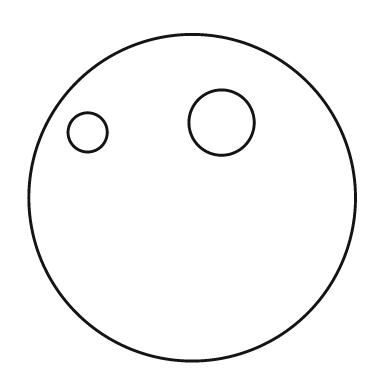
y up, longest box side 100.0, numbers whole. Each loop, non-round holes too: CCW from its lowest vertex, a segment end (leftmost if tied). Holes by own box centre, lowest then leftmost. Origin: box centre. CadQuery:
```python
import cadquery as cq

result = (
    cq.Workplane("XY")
    .moveTo(0.0, 0.0)
    .circle(50.0)
    .moveTo(-32.0, 20.0)
    .circle(6.0)
    .moveTo(9.0, 23.0)
    .circle(10.0)
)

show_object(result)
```